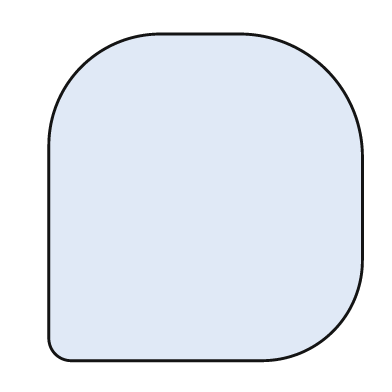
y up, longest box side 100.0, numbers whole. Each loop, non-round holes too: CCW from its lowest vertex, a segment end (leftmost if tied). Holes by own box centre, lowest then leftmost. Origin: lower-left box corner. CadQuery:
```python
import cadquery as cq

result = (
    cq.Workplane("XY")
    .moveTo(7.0, 0.0)
    .lineTo(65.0, 0.0)
    .threePointArc((87.0, 9.0), (96.0, 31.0))
    .lineTo(96.0, 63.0)
    .threePointArc((85.0, 89.0), (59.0, 100.0))
    .lineTo(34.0, 100.0)
    .threePointArc((10.0, 90.0), (0.0, 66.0))
    .lineTo(0.0, 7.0)
    .threePointArc((2.0, 2.0), (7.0, 0.0))
    .close()
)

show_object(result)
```